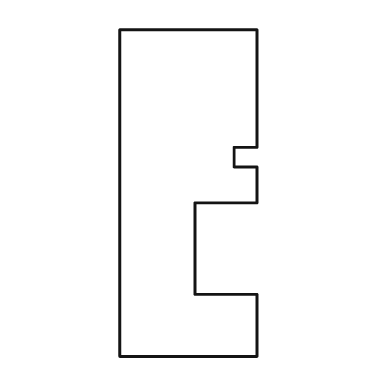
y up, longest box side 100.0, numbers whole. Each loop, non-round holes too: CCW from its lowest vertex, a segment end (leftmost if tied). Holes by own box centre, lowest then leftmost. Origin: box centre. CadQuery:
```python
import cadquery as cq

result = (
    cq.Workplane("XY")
    .moveTo(-21.0, -50.0)
    .lineTo(21.0, -50.0)
    .lineTo(21.0, -31.0)
    .lineTo(2.0, -31.0)
    .lineTo(2.0, -3.0)
    .lineTo(21.0, -3.0)
    .lineTo(21.0, 8.0)
    .lineTo(14.0, 8.0)
    .lineTo(14.0, 14.0)
    .lineTo(21.0, 14.0)
    .lineTo(21.0, 50.0)
    .lineTo(-21.0, 50.0)
    .close()
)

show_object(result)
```